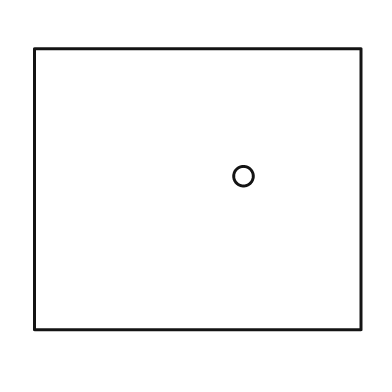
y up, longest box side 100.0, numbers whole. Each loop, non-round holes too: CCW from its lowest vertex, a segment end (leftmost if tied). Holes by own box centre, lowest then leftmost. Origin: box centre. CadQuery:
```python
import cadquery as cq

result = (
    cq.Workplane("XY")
    .moveTo(-50.0, -43.0)
    .lineTo(50.0, -43.0)
    .lineTo(50.0, 43.0)
    .lineTo(-50.0, 43.0)
    .close()
    .moveTo(14.0, 4.0)
    .circle(3.0)
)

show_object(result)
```